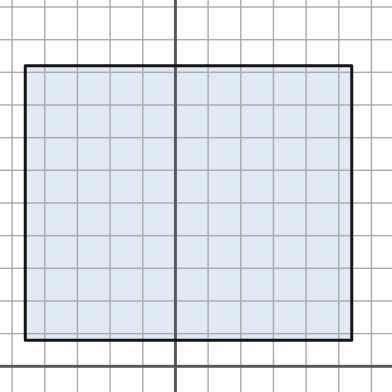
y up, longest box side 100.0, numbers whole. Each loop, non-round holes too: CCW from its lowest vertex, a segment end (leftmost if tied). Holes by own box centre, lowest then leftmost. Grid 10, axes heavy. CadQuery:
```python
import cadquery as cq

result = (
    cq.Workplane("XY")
    .moveTo(-46.0, 8.0)
    .lineTo(54.0, 8.0)
    .lineTo(54.0, 92.0)
    .lineTo(-46.0, 92.0)
    .close()
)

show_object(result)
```